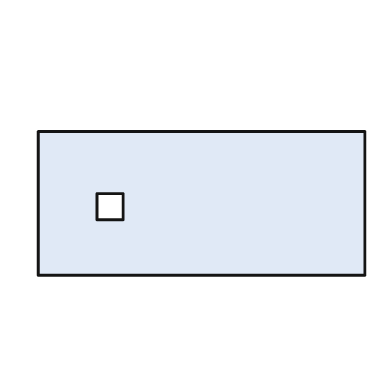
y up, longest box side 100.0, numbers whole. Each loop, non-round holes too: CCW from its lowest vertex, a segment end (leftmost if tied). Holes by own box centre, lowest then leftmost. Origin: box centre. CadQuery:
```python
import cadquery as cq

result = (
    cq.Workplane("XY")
    .moveTo(-50.0, -22.0)
    .lineTo(50.0, -22.0)
    .lineTo(50.0, 22.0)
    .lineTo(-50.0, 22.0)
    .close()
    .moveTo(-32.0, -5.0)
    .lineTo(-24.0, -5.0)
    .lineTo(-24.0, 3.0)
    .lineTo(-32.0, 3.0)
    .close()
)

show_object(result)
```